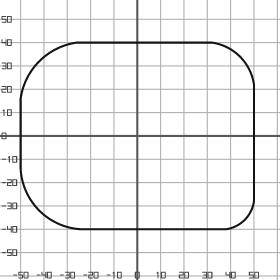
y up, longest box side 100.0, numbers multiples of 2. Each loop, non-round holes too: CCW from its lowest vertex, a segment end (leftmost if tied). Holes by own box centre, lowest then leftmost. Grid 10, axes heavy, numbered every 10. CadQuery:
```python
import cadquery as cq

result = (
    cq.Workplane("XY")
    .moveTo(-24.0, -40.0)
    .lineTo(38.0, -40.0)
    .threePointArc((46.0, -36.0), (50.0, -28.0))
    .lineTo(50.0, 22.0)
    .threePointArc((44.0, 34.0), (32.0, 40.0))
    .lineTo(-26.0, 40.0)
    .threePointArc((-42.0, 32.0), (-50.0, 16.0))
    .lineTo(-50.0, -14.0)
    .threePointArc((-42.0, -32.0), (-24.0, -40.0))
    .close()
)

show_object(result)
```